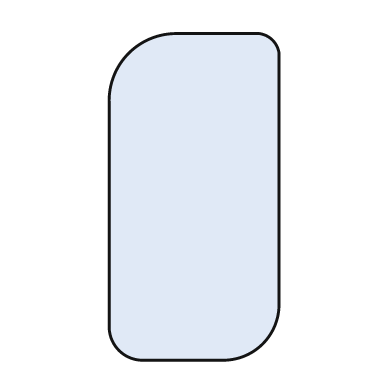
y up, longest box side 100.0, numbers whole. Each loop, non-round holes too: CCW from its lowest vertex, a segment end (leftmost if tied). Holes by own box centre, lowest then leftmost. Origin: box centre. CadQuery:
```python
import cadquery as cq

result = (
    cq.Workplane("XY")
    .moveTo(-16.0, -50.0)
    .lineTo(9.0, -50.0)
    .threePointArc((21.0, -45.0), (26.0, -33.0))
    .lineTo(26.0, 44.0)
    .threePointArc((24.0, 48.0), (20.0, 50.0))
    .lineTo(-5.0, 50.0)
    .threePointArc((-20.0, 44.0), (-26.0, 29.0))
    .lineTo(-26.0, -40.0)
    .threePointArc((-23.0, -47.0), (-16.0, -50.0))
    .close()
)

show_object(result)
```